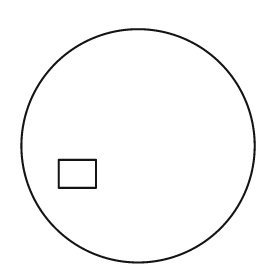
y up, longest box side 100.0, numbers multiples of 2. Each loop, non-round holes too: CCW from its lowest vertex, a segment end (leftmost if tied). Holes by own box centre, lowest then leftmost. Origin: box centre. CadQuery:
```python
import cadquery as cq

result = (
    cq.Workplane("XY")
    .moveTo(0.0, 0.0)
    .circle(50.0)
    .moveTo(-34.0, -18.0)
    .lineTo(-18.0, -18.0)
    .lineTo(-18.0, -6.0)
    .lineTo(-34.0, -6.0)
    .close()
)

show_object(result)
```